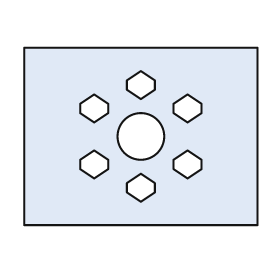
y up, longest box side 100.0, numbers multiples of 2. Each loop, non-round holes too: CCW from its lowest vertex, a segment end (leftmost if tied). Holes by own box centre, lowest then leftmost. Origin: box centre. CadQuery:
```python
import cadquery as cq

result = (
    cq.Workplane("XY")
    .moveTo(-50.0, -38.0)
    .lineTo(50.0, -38.0)
    .lineTo(50.0, 38.0)
    .lineTo(-50.0, 38.0)
    .close()
    .moveTo(0.0, -28.0)
    .lineTo(6.0, -24.0)
    .lineTo(6.0, -20.0)
    .lineTo(0.0, -16.0)
    .lineTo(-6.0, -20.0)
    .lineTo(-6.0, -24.0)
    .close()
    .moveTo(-20.0, -18.0)
    .lineTo(-14.0, -14.0)
    .lineTo(-14.0, -10.0)
    .lineTo(-20.0, -6.0)
    .lineTo(-26.0, -10.0)
    .lineTo(-26.0, -14.0)
    .close()
    .moveTo(20.0, -18.0)
    .lineTo(26.0, -14.0)
    .lineTo(26.0, -10.0)
    .lineTo(20.0, -6.0)
    .lineTo(14.0, -10.0)
    .lineTo(14.0, -14.0)
    .close()
    .moveTo(0.0, 0.0)
    .circle(10.0)
    .moveTo(-20.0, 6.0)
    .lineTo(-14.0, 10.0)
    .lineTo(-14.0, 14.0)
    .lineTo(-20.0, 18.0)
    .lineTo(-26.0, 14.0)
    .lineTo(-26.0, 10.0)
    .close()
    .moveTo(20.0, 6.0)
    .lineTo(26.0, 10.0)
    .lineTo(26.0, 14.0)
    .lineTo(20.0, 18.0)
    .lineTo(14.0, 14.0)
    .lineTo(14.0, 10.0)
    .close()
    .moveTo(0.0, 16.0)
    .lineTo(6.0, 20.0)
    .lineTo(6.0, 24.0)
    .lineTo(0.0, 28.0)
    .lineTo(-6.0, 24.0)
    .lineTo(-6.0, 20.0)
    .close()
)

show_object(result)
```